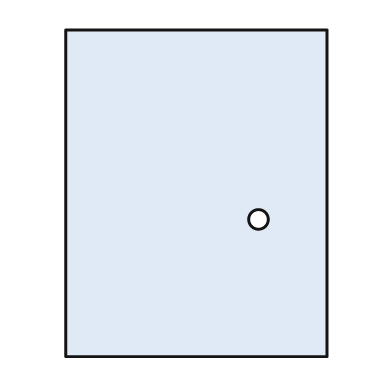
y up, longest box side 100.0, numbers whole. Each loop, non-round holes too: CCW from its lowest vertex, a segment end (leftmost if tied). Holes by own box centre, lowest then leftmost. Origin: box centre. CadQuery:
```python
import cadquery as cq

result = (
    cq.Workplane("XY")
    .moveTo(-40.0, -50.0)
    .lineTo(40.0, -50.0)
    .lineTo(40.0, 50.0)
    .lineTo(-40.0, 50.0)
    .close()
    .moveTo(19.0, -8.0)
    .circle(3.0)
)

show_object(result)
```